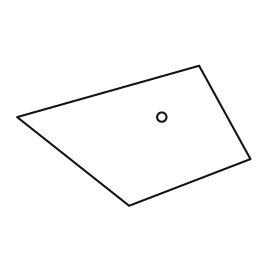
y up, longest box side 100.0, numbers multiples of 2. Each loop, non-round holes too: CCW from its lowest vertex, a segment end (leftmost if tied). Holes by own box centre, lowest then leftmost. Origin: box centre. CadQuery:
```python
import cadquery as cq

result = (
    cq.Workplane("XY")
    .moveTo(-2.0, -30.0)
    .lineTo(50.0, -10.0)
    .lineTo(28.0, 30.0)
    .lineTo(-50.0, 8.0)
    .close()
    .moveTo(12.0, 8.0)
    .circle(2.0)
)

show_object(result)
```